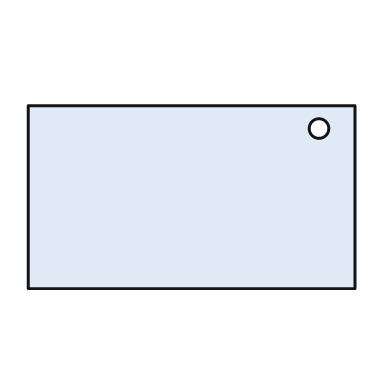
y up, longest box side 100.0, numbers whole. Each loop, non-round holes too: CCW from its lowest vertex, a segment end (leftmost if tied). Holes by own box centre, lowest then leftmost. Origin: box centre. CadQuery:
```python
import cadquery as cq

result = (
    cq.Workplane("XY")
    .moveTo(-50.0, -28.0)
    .lineTo(50.0, -28.0)
    .lineTo(50.0, 28.0)
    .lineTo(-50.0, 28.0)
    .close()
    .moveTo(39.0, 21.0)
    .circle(3.0)
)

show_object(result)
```